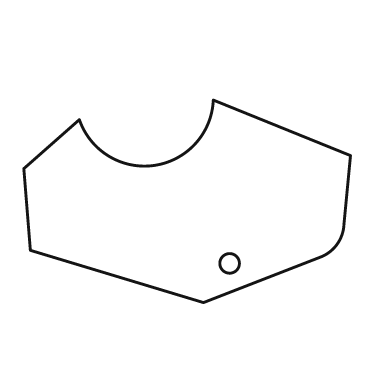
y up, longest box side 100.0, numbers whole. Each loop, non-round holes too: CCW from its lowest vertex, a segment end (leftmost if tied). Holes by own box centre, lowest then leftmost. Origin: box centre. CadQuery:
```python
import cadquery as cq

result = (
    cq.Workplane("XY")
    .moveTo(5.0, -31.0)
    .lineTo(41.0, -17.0)
    .threePointArc((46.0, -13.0), (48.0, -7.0))
    .lineTo(50.0, 14.0)
    .lineTo(8.0, 31.0)
    .threePointArc((-10.0, 11.0), (-33.0, 25.0))
    .lineTo(-50.0, 10.0)
    .lineTo(-48.0, -15.0)
    .close()
    .moveTo(13.0, -19.0)
    .circle(3.0)
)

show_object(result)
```